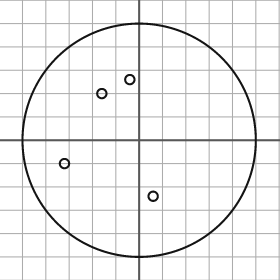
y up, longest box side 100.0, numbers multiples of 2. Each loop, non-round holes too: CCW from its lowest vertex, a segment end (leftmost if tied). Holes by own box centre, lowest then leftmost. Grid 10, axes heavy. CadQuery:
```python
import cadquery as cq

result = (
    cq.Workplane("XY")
    .moveTo(0.0, 0.0)
    .circle(50.0)
    .moveTo(6.0, -24.0)
    .circle(2.0)
    .moveTo(-32.0, -10.0)
    .circle(2.0)
    .moveTo(-16.0, 20.0)
    .circle(2.0)
    .moveTo(-4.0, 26.0)
    .circle(2.0)
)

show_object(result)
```